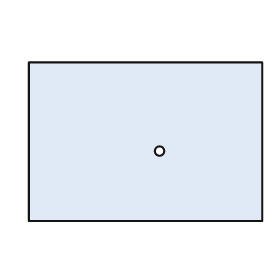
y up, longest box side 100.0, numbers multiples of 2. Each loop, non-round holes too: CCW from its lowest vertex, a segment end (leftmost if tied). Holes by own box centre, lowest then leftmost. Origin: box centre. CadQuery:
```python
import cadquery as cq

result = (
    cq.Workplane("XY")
    .moveTo(-50.0, -34.0)
    .lineTo(50.0, -34.0)
    .lineTo(50.0, 34.0)
    .lineTo(-50.0, 34.0)
    .close()
    .moveTo(6.0, -4.0)
    .circle(2.0)
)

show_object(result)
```